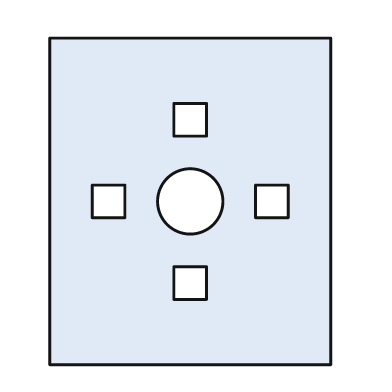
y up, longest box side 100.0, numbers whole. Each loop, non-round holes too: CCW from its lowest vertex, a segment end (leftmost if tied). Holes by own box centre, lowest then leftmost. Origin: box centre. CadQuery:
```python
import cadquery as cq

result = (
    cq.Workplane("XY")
    .moveTo(-43.0, -50.0)
    .lineTo(43.0, -50.0)
    .lineTo(43.0, 50.0)
    .lineTo(-43.0, 50.0)
    .close()
    .moveTo(-5.0, -30.0)
    .lineTo(5.0, -30.0)
    .lineTo(5.0, -20.0)
    .lineTo(-5.0, -20.0)
    .close()
    .moveTo(-30.0, -5.0)
    .lineTo(-20.0, -5.0)
    .lineTo(-20.0, 5.0)
    .lineTo(-30.0, 5.0)
    .close()
    .moveTo(0.0, 0.0)
    .circle(10.0)
    .moveTo(20.0, -5.0)
    .lineTo(30.0, -5.0)
    .lineTo(30.0, 5.0)
    .lineTo(20.0, 5.0)
    .close()
    .moveTo(-5.0, 20.0)
    .lineTo(5.0, 20.0)
    .lineTo(5.0, 30.0)
    .lineTo(-5.0, 30.0)
    .close()
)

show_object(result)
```